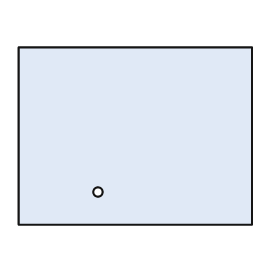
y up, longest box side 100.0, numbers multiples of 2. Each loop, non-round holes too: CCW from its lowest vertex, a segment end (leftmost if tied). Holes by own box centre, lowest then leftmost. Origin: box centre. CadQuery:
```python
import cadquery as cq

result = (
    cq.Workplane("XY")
    .moveTo(-50.0, -38.0)
    .lineTo(50.0, -38.0)
    .lineTo(50.0, 38.0)
    .lineTo(-50.0, 38.0)
    .close()
    .moveTo(-16.0, -24.0)
    .circle(2.0)
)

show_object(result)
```